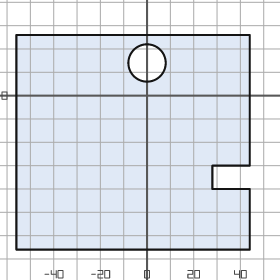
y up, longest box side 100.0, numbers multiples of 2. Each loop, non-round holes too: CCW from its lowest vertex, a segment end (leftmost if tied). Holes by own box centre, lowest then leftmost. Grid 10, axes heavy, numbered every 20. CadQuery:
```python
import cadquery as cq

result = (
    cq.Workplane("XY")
    .moveTo(-56.0, -66.0)
    .lineTo(44.0, -66.0)
    .lineTo(44.0, -40.0)
    .lineTo(28.0, -40.0)
    .lineTo(28.0, -30.0)
    .lineTo(44.0, -30.0)
    .lineTo(44.0, 26.0)
    .lineTo(-56.0, 26.0)
    .close()
    .moveTo(0.0, 14.0)
    .circle(8.0)
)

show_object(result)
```